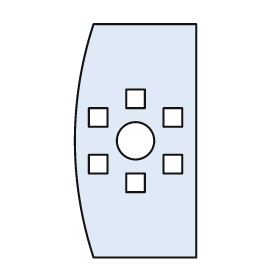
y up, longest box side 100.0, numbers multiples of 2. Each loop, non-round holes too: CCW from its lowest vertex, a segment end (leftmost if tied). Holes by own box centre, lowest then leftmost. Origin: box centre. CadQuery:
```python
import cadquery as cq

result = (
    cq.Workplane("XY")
    .moveTo(-18.0, -50.0)
    .lineTo(26.0, -50.0)
    .lineTo(26.0, 50.0)
    .lineTo(-18.0, 50.0)
    .threePointArc((-26.0, 0.0), (-18.0, -50.0))
    .close()
    .moveTo(-4.0, -22.0)
    .lineTo(4.0, -22.0)
    .lineTo(4.0, -14.0)
    .lineTo(-4.0, -14.0)
    .close()
    .moveTo(-20.0, -14.0)
    .lineTo(-12.0, -14.0)
    .lineTo(-12.0, -6.0)
    .lineTo(-20.0, -6.0)
    .close()
    .moveTo(12.0, -14.0)
    .lineTo(20.0, -14.0)
    .lineTo(20.0, -6.0)
    .lineTo(12.0, -6.0)
    .close()
    .moveTo(0.0, 0.0)
    .circle(8.0)
    .moveTo(-20.0, 6.0)
    .lineTo(-12.0, 6.0)
    .lineTo(-12.0, 14.0)
    .lineTo(-20.0, 14.0)
    .close()
    .moveTo(12.0, 6.0)
    .lineTo(20.0, 6.0)
    .lineTo(20.0, 14.0)
    .lineTo(12.0, 14.0)
    .close()
    .moveTo(-4.0, 14.0)
    .lineTo(4.0, 14.0)
    .lineTo(4.0, 22.0)
    .lineTo(-4.0, 22.0)
    .close()
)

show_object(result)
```